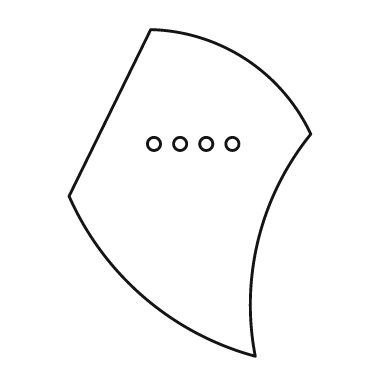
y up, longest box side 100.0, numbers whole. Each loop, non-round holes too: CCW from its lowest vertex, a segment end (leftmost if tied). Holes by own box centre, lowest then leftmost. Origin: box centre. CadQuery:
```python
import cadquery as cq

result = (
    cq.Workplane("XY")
    .moveTo(20.0, -50.0)
    .threePointArc((21.0, -14.0), (37.0, 18.0))
    .threePointArc((17.0, 41.0), (-12.0, 50.0))
    .lineTo(-37.0, -1.0)
    .threePointArc((-14.0, -32.0), (20.0, -50.0))
    .close()
    .moveTo(-11.0, 15.0)
    .circle(2.0)
    .moveTo(-3.0, 15.0)
    .circle(2.0)
    .moveTo(5.0, 15.0)
    .circle(2.0)
    .moveTo(13.0, 15.0)
    .circle(2.0)
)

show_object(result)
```